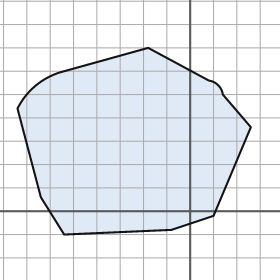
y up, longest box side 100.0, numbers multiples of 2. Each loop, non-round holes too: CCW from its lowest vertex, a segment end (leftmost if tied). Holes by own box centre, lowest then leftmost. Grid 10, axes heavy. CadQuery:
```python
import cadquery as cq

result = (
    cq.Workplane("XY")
    .moveTo(-54.0, -10.0)
    .lineTo(-8.0, -8.0)
    .lineTo(10.0, -2.0)
    .lineTo(26.0, 36.0)
    .lineTo(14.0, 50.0)
    .threePointArc((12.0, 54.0), (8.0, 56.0))
    .lineTo(-18.0, 70.0)
    .lineTo(-54.0, 60.0)
    .threePointArc((-66.0, 54.0), (-74.0, 44.0))
    .lineTo(-64.0, 6.0)
    .close()
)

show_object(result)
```